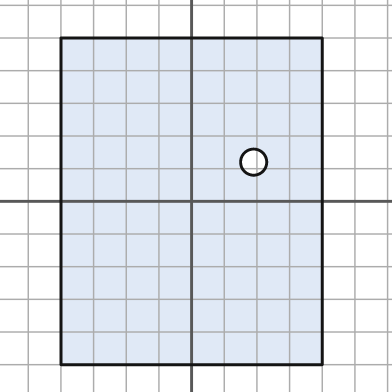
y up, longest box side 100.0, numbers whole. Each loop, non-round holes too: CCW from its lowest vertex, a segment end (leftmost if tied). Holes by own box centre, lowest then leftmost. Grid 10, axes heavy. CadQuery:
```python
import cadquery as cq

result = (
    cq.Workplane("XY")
    .moveTo(-40.0, -50.0)
    .lineTo(40.0, -50.0)
    .lineTo(40.0, 50.0)
    .lineTo(-40.0, 50.0)
    .close()
    .moveTo(19.0, 12.0)
    .circle(4.0)
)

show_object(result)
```